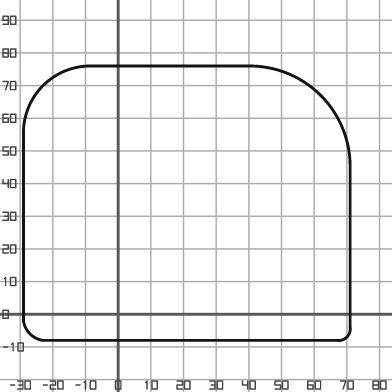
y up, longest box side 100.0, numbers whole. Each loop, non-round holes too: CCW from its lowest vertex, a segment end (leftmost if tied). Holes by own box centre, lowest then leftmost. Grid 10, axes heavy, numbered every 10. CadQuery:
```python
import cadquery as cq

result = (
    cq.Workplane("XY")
    .moveTo(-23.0, -8.0)
    .lineTo(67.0, -8.0)
    .threePointArc((70.0, -7.0), (71.0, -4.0))
    .lineTo(71.0, 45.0)
    .threePointArc((62.0, 67.0), (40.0, 76.0))
    .lineTo(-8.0, 76.0)
    .threePointArc((-23.0, 70.0), (-29.0, 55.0))
    .lineTo(-29.0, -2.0)
    .threePointArc((-27.0, -6.0), (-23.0, -8.0))
    .close()
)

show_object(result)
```